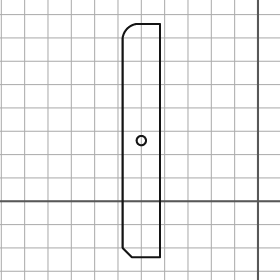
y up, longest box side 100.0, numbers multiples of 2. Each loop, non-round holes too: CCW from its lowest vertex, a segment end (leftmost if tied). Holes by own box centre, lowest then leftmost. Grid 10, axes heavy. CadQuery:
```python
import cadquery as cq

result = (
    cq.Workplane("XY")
    .moveTo(-54.0, -24.0)
    .lineTo(-42.0, -24.0)
    .lineTo(-42.0, 76.0)
    .lineTo(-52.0, 76.0)
    .threePointArc((-56.0, 74.0), (-58.0, 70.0))
    .lineTo(-58.0, -20.0)
    .close()
    .moveTo(-50.0, 26.0)
    .circle(2.0)
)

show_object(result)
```